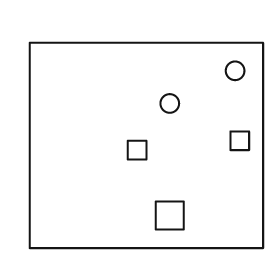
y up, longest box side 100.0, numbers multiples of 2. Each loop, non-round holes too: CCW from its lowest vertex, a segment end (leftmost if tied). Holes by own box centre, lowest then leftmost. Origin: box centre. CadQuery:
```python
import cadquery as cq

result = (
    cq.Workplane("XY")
    .moveTo(-50.0, -44.0)
    .lineTo(50.0, -44.0)
    .lineTo(50.0, 44.0)
    .lineTo(-50.0, 44.0)
    .close()
    .moveTo(4.0, -36.0)
    .lineTo(16.0, -36.0)
    .lineTo(16.0, -24.0)
    .lineTo(4.0, -24.0)
    .close()
    .moveTo(-8.0, -6.0)
    .lineTo(0.0, -6.0)
    .lineTo(0.0, 2.0)
    .lineTo(-8.0, 2.0)
    .close()
    .moveTo(36.0, -2.0)
    .lineTo(44.0, -2.0)
    .lineTo(44.0, 6.0)
    .lineTo(36.0, 6.0)
    .close()
    .moveTo(10.0, 18.0)
    .circle(4.0)
    .moveTo(38.0, 32.0)
    .circle(4.0)
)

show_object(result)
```